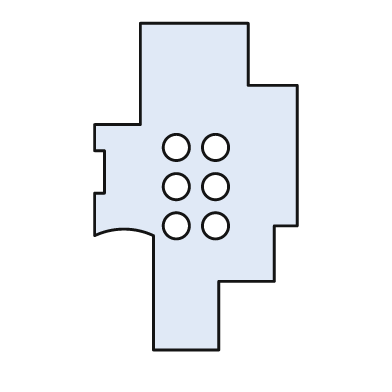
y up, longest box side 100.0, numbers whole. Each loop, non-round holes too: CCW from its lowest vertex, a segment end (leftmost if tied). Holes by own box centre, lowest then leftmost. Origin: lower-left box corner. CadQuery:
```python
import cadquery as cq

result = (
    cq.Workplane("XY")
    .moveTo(18.0, 0.0)
    .lineTo(38.0, 0.0)
    .lineTo(38.0, 21.0)
    .lineTo(55.0, 21.0)
    .lineTo(55.0, 38.0)
    .lineTo(62.0, 38.0)
    .lineTo(62.0, 81.0)
    .lineTo(47.0, 81.0)
    .lineTo(47.0, 100.0)
    .lineTo(14.0, 100.0)
    .lineTo(14.0, 69.0)
    .lineTo(0.0, 69.0)
    .lineTo(0.0, 61.0)
    .lineTo(3.0, 61.0)
    .lineTo(3.0, 48.0)
    .lineTo(0.0, 48.0)
    .lineTo(0.0, 35.0)
    .threePointArc((9.0, 37.0), (18.0, 35.0))
    .close()
    .moveTo(25.0, 38.0)
    .circle(4.0)
    .moveTo(37.0, 38.0)
    .circle(4.0)
    .moveTo(25.0, 50.0)
    .circle(4.0)
    .moveTo(37.0, 50.0)
    .circle(4.0)
    .moveTo(25.0, 62.0)
    .circle(4.0)
    .moveTo(37.0, 62.0)
    .circle(4.0)
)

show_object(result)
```